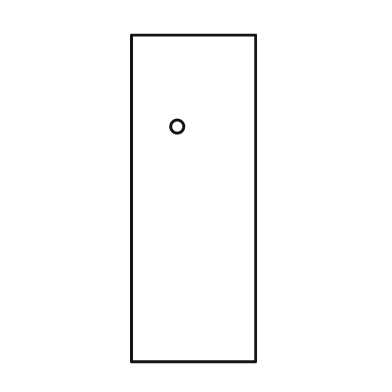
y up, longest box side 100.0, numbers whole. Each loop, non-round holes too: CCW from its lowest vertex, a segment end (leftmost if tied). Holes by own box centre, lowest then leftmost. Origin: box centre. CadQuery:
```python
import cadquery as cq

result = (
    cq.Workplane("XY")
    .moveTo(-19.0, -50.0)
    .lineTo(19.0, -50.0)
    .lineTo(19.0, 50.0)
    .lineTo(-19.0, 50.0)
    .close()
    .moveTo(-5.0, 22.0)
    .circle(2.0)
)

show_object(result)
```